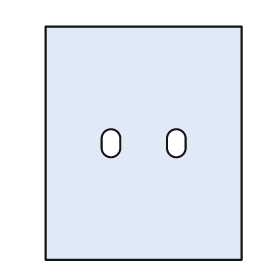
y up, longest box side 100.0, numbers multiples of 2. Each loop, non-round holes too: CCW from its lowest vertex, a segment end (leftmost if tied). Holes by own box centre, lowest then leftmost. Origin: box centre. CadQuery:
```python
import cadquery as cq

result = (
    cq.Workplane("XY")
    .moveTo(-42.0, -50.0)
    .lineTo(42.0, -50.0)
    .lineTo(42.0, 50.0)
    .lineTo(-42.0, 50.0)
    .close()
    .moveTo(-18.0, -2.0)
    .threePointArc((-14.0, -6.0), (-10.0, -2.0))
    .lineTo(-10.0, 2.0)
    .threePointArc((-14.0, 6.0), (-18.0, 2.0))
    .close()
    .moveTo(10.0, -2.0)
    .threePointArc((14.0, -6.0), (18.0, -2.0))
    .lineTo(18.0, 2.0)
    .threePointArc((14.0, 6.0), (10.0, 2.0))
    .close()
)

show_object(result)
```